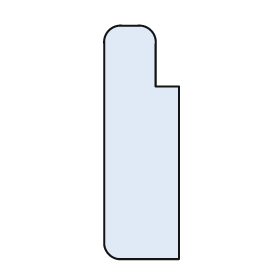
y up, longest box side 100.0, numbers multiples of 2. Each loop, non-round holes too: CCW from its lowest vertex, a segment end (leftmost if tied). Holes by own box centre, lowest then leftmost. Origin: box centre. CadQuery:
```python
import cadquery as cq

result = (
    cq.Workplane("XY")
    .moveTo(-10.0, -50.0)
    .lineTo(16.0, -50.0)
    .lineTo(16.0, 24.0)
    .lineTo(6.0, 24.0)
    .lineTo(6.0, 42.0)
    .threePointArc((4.0, 48.0), (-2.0, 50.0))
    .lineTo(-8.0, 50.0)
    .threePointArc((-14.0, 48.0), (-16.0, 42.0))
    .lineTo(-16.0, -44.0)
    .threePointArc((-14.0, -48.0), (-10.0, -50.0))
    .close()
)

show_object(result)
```